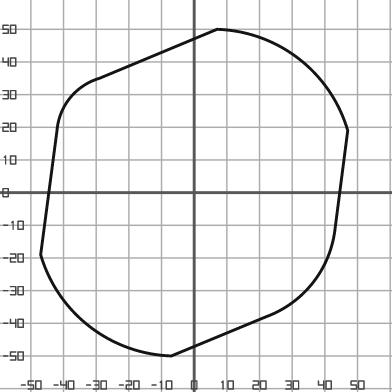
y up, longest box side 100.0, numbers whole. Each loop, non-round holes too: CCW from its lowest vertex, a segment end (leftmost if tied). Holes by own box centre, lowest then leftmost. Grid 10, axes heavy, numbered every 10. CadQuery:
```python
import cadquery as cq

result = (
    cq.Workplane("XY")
    .moveTo(-7.0, -50.0)
    .lineTo(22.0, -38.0)
    .threePointArc((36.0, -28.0), (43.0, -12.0))
    .lineTo(47.0, 19.0)
    .threePointArc((32.0, 41.0), (7.0, 50.0))
    .lineTo(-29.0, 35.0)
    .threePointArc((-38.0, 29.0), (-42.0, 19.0))
    .lineTo(-47.0, -19.0)
    .threePointArc((-32.0, -41.0), (-7.0, -50.0))
    .close()
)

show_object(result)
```